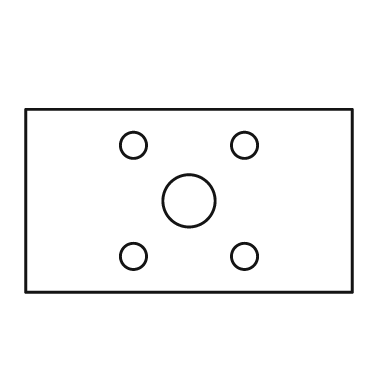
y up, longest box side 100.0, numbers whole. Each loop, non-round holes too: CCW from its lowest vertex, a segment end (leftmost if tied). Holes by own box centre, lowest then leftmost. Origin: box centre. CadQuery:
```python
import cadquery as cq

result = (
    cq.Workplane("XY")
    .moveTo(-50.0, -28.0)
    .lineTo(50.0, -28.0)
    .lineTo(50.0, 28.0)
    .lineTo(-50.0, 28.0)
    .close()
    .moveTo(-17.0, -17.0)
    .circle(4.0)
    .moveTo(17.0, -17.0)
    .circle(4.0)
    .moveTo(0.0, 0.0)
    .circle(8.0)
    .moveTo(-17.0, 17.0)
    .circle(4.0)
    .moveTo(17.0, 17.0)
    .circle(4.0)
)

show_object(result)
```